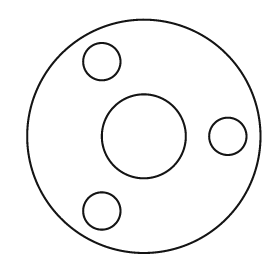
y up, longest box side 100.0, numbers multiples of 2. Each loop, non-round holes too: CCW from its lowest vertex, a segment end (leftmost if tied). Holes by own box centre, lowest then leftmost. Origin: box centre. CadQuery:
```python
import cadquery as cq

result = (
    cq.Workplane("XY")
    .moveTo(0.0, 0.0)
    .circle(50.0)
    .moveTo(-18.0, -32.0)
    .circle(8.0)
    .moveTo(0.0, 0.0)
    .circle(18.0)
    .moveTo(36.0, 0.0)
    .circle(8.0)
    .moveTo(-18.0, 32.0)
    .circle(8.0)
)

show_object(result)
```